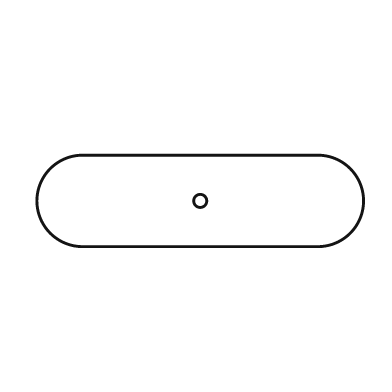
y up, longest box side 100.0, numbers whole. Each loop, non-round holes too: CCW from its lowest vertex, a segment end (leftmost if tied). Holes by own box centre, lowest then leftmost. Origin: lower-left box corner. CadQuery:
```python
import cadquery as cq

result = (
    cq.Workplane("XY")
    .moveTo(14.0, 0.0)
    .lineTo(86.0, 0.0)
    .threePointArc((100.0, 14.0), (86.0, 28.0))
    .lineTo(14.0, 28.0)
    .threePointArc((0.0, 14.0), (14.0, 0.0))
    .close()
    .moveTo(50.0, 14.0)
    .circle(2.0)
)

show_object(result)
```